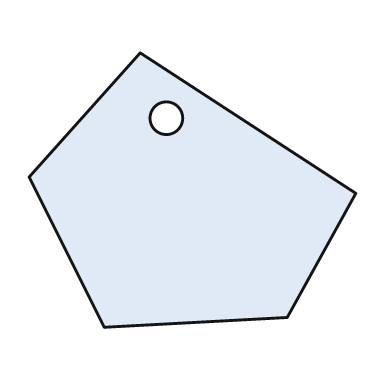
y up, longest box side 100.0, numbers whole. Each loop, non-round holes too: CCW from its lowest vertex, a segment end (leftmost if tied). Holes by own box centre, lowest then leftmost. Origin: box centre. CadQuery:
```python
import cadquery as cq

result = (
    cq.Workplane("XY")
    .moveTo(-27.0, -42.0)
    .lineTo(29.0, -39.0)
    .lineTo(50.0, -1.0)
    .lineTo(-16.0, 42.0)
    .lineTo(-50.0, 4.0)
    .close()
    .moveTo(-8.0, 22.0)
    .circle(5.0)
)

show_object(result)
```